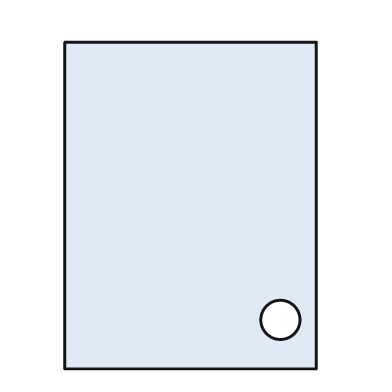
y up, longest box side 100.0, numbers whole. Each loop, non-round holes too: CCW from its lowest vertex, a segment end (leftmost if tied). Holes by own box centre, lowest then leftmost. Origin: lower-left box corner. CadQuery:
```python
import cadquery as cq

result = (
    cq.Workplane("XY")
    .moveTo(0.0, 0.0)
    .lineTo(77.0, 0.0)
    .lineTo(77.0, 100.0)
    .lineTo(0.0, 100.0)
    .close()
    .moveTo(66.0, 15.0)
    .circle(6.0)
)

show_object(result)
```